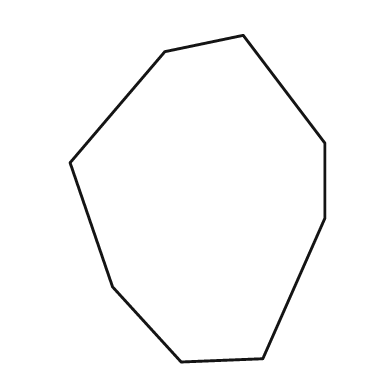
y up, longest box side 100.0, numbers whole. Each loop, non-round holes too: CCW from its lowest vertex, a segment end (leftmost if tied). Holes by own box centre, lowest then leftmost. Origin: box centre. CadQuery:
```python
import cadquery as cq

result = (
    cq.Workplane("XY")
    .moveTo(-5.0, -50.0)
    .lineTo(20.0, -49.0)
    .lineTo(39.0, -6.0)
    .lineTo(39.0, 17.0)
    .lineTo(14.0, 50.0)
    .lineTo(-10.0, 45.0)
    .lineTo(-39.0, 11.0)
    .lineTo(-26.0, -27.0)
    .close()
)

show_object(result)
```